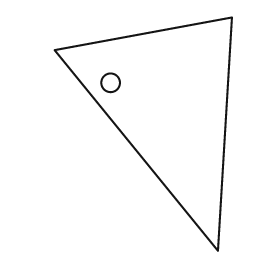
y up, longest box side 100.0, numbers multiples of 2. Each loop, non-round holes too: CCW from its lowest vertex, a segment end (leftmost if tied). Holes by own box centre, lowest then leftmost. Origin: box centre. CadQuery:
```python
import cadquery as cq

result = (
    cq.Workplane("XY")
    .moveTo(32.0, -50.0)
    .lineTo(38.0, 50.0)
    .lineTo(-38.0, 36.0)
    .close()
    .moveTo(-14.0, 22.0)
    .circle(4.0)
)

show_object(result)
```